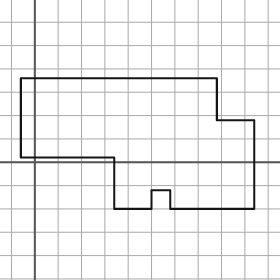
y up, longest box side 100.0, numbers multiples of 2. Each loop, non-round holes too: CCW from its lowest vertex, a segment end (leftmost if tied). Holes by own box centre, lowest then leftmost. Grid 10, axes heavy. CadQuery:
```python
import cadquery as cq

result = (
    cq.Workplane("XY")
    .moveTo(34.0, -20.0)
    .lineTo(50.0, -20.0)
    .lineTo(50.0, -12.0)
    .lineTo(58.0, -12.0)
    .lineTo(58.0, -20.0)
    .lineTo(94.0, -20.0)
    .lineTo(94.0, 18.0)
    .lineTo(78.0, 18.0)
    .lineTo(78.0, 36.0)
    .lineTo(-6.0, 36.0)
    .lineTo(-6.0, 2.0)
    .lineTo(34.0, 2.0)
    .close()
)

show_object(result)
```